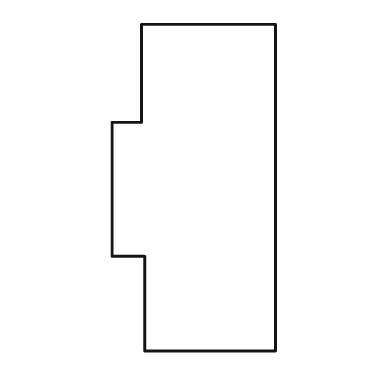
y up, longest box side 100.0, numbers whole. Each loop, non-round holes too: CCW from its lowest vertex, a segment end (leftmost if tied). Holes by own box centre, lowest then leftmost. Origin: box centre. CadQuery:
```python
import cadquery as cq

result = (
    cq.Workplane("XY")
    .moveTo(-15.0, -50.0)
    .lineTo(25.0, -50.0)
    .lineTo(25.0, 50.0)
    .lineTo(-16.0, 50.0)
    .lineTo(-16.0, 20.0)
    .lineTo(-25.0, 20.0)
    .lineTo(-25.0, -21.0)
    .lineTo(-15.0, -21.0)
    .close()
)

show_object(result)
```